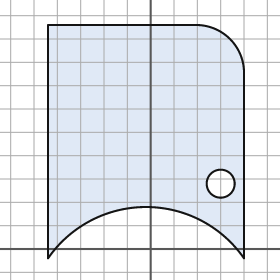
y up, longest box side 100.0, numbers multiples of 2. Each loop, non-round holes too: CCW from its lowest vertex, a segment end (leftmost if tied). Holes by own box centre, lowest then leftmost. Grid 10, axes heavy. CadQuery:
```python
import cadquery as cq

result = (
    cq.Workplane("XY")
    .moveTo(-44.0, -4.0)
    .threePointArc((-2.0, 18.0), (40.0, -4.0))
    .lineTo(40.0, 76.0)
    .threePointArc((34.0, 90.0), (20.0, 96.0))
    .lineTo(-44.0, 96.0)
    .close()
    .moveTo(30.0, 28.0)
    .circle(6.0)
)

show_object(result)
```